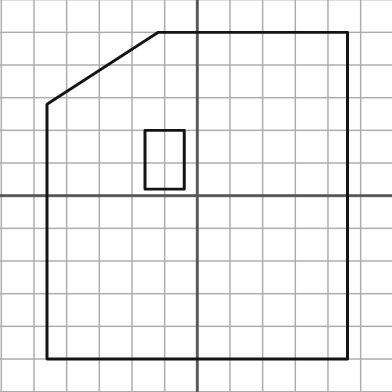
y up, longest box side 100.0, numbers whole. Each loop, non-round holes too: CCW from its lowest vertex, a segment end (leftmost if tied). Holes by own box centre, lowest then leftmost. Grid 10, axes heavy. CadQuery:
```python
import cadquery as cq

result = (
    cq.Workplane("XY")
    .moveTo(-46.0, -50.0)
    .lineTo(46.0, -50.0)
    .lineTo(46.0, 50.0)
    .lineTo(-12.0, 50.0)
    .lineTo(-46.0, 28.0)
    .close()
    .moveTo(-16.0, 2.0)
    .lineTo(-4.0, 2.0)
    .lineTo(-4.0, 20.0)
    .lineTo(-16.0, 20.0)
    .close()
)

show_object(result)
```